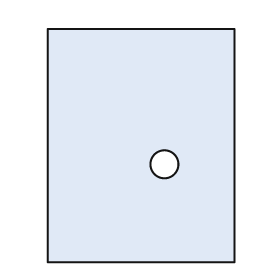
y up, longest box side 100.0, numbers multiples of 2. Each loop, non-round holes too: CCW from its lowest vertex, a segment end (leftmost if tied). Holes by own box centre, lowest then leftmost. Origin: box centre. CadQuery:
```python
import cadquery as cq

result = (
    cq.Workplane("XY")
    .moveTo(-40.0, -50.0)
    .lineTo(40.0, -50.0)
    .lineTo(40.0, 50.0)
    .lineTo(-40.0, 50.0)
    .close()
    .moveTo(10.0, -8.0)
    .circle(6.0)
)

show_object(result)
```